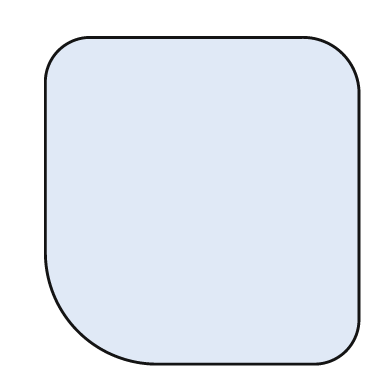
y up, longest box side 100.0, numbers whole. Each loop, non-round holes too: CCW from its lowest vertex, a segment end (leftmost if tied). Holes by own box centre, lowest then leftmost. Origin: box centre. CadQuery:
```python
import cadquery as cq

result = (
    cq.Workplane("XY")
    .moveTo(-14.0, -50.0)
    .lineTo(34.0, -50.0)
    .threePointArc((44.0, -46.0), (48.0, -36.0))
    .lineTo(48.0, 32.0)
    .threePointArc((43.0, 45.0), (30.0, 50.0))
    .lineTo(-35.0, 50.0)
    .threePointArc((-44.0, 46.0), (-48.0, 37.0))
    .lineTo(-48.0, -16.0)
    .threePointArc((-38.0, -40.0), (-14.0, -50.0))
    .close()
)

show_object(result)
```